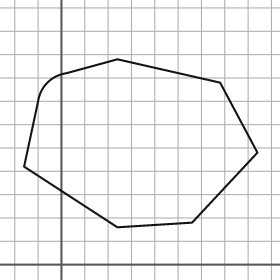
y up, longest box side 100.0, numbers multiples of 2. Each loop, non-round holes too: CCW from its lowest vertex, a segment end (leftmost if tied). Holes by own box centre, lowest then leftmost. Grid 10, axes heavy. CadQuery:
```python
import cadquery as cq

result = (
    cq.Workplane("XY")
    .moveTo(24.0, 16.0)
    .lineTo(56.0, 18.0)
    .lineTo(84.0, 48.0)
    .lineTo(68.0, 78.0)
    .lineTo(24.0, 88.0)
    .lineTo(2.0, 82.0)
    .threePointArc((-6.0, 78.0), (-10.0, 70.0))
    .lineTo(-16.0, 42.0)
    .close()
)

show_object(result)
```